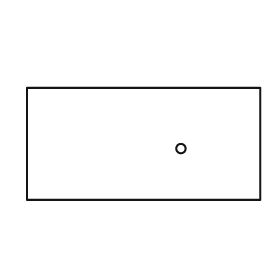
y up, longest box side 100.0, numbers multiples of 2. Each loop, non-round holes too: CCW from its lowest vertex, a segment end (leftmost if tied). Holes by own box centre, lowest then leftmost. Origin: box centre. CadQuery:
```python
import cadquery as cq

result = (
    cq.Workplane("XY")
    .moveTo(-50.0, -24.0)
    .lineTo(50.0, -24.0)
    .lineTo(50.0, 24.0)
    .lineTo(-50.0, 24.0)
    .close()
    .moveTo(16.0, -2.0)
    .circle(2.0)
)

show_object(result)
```